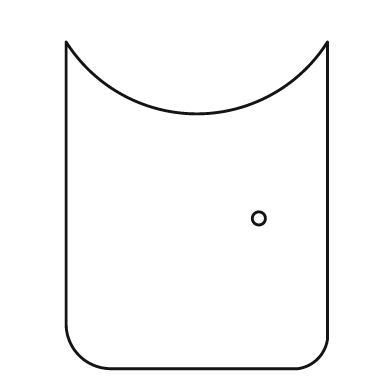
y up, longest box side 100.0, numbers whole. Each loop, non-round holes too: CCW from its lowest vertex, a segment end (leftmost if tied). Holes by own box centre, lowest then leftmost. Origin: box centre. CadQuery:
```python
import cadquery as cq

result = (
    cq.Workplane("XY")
    .moveTo(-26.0, -50.0)
    .lineTo(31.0, -50.0)
    .threePointArc((37.0, -47.0), (40.0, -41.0))
    .lineTo(40.0, 50.0)
    .threePointArc((0.0, 28.0), (-40.0, 50.0))
    .lineTo(-40.0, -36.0)
    .threePointArc((-36.0, -46.0), (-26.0, -50.0))
    .close()
    .moveTo(19.0, -4.0)
    .circle(2.0)
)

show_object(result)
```